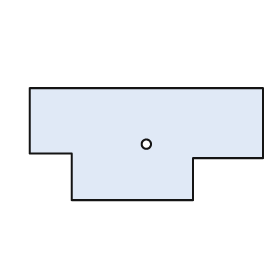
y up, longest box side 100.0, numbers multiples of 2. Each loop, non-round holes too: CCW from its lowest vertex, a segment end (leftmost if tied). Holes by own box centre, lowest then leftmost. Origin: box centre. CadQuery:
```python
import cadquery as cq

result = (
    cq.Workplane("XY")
    .moveTo(-32.0, -24.0)
    .lineTo(20.0, -24.0)
    .lineTo(20.0, -6.0)
    .lineTo(50.0, -6.0)
    .lineTo(50.0, 24.0)
    .lineTo(-50.0, 24.0)
    .lineTo(-50.0, -4.0)
    .lineTo(-32.0, -4.0)
    .close()
    .moveTo(0.0, 0.0)
    .circle(2.0)
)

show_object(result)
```